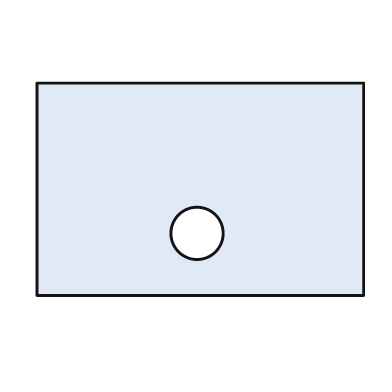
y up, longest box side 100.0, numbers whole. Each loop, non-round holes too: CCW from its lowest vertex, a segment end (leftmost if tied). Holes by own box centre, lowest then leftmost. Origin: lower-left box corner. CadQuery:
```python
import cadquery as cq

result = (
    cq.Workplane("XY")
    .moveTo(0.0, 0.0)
    .lineTo(100.0, 0.0)
    .lineTo(100.0, 65.0)
    .lineTo(0.0, 65.0)
    .close()
    .moveTo(49.0, 19.0)
    .circle(8.0)
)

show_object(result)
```